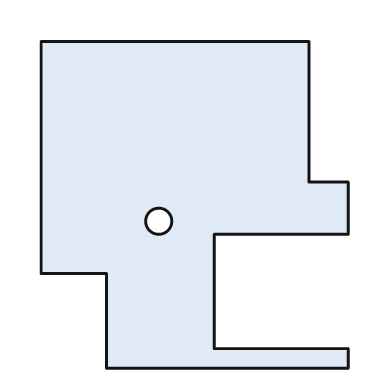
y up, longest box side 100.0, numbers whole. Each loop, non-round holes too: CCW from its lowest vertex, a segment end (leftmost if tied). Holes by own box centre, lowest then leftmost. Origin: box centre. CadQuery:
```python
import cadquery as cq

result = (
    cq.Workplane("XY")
    .moveTo(-27.0, -50.0)
    .lineTo(47.0, -50.0)
    .lineTo(47.0, -44.0)
    .lineTo(6.0, -44.0)
    .lineTo(6.0, -9.0)
    .lineTo(47.0, -9.0)
    .lineTo(47.0, 7.0)
    .lineTo(35.0, 7.0)
    .lineTo(35.0, 50.0)
    .lineTo(-47.0, 50.0)
    .lineTo(-47.0, -21.0)
    .lineTo(-27.0, -21.0)
    .close()
    .moveTo(-11.0, -5.0)
    .circle(4.0)
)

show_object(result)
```